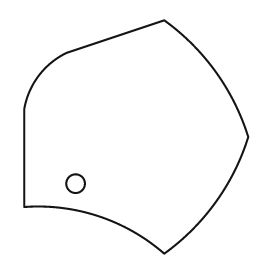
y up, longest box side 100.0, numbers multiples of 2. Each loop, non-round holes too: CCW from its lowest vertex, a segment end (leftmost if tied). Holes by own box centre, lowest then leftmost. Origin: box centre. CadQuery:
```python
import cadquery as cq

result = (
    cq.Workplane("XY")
    .moveTo(12.0, -50.0)
    .threePointArc((34.0, -28.0), (48.0, 0.0))
    .threePointArc((34.0, 28.0), (12.0, 50.0))
    .lineTo(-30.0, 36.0)
    .threePointArc((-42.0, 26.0), (-48.0, 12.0))
    .lineTo(-48.0, -30.0)
    .threePointArc((-16.0, -34.0), (12.0, -50.0))
    .close()
    .moveTo(-26.0, -20.0)
    .circle(4.0)
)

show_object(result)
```